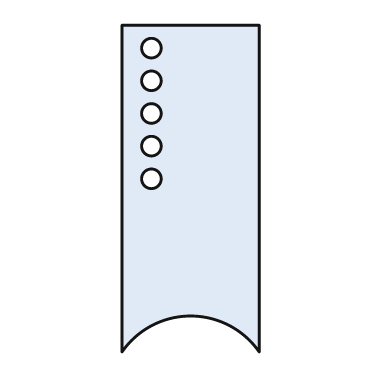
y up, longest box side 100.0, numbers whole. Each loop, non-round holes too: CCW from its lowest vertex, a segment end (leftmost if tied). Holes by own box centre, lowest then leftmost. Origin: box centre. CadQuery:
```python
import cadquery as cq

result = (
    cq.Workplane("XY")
    .moveTo(-21.0, -50.0)
    .threePointArc((0.0, -39.0), (21.0, -50.0))
    .lineTo(21.0, 50.0)
    .lineTo(-21.0, 50.0)
    .close()
    .moveTo(-12.0, 3.0)
    .circle(3.0)
    .moveTo(-12.0, 13.0)
    .circle(3.0)
    .moveTo(-12.0, 23.0)
    .circle(3.0)
    .moveTo(-12.0, 33.0)
    .circle(3.0)
    .moveTo(-12.0, 43.0)
    .circle(3.0)
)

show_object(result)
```